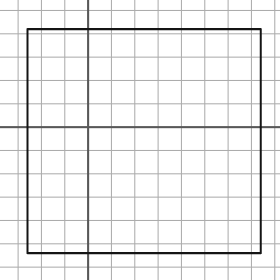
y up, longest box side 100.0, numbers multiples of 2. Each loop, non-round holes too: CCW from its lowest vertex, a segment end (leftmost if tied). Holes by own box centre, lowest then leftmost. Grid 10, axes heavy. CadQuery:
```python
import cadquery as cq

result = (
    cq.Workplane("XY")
    .moveTo(-26.0, -54.0)
    .lineTo(74.0, -54.0)
    .lineTo(74.0, 42.0)
    .lineTo(-26.0, 42.0)
    .close()
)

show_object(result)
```